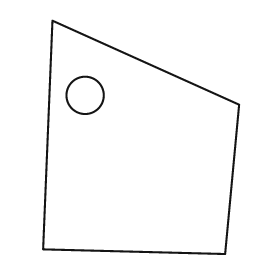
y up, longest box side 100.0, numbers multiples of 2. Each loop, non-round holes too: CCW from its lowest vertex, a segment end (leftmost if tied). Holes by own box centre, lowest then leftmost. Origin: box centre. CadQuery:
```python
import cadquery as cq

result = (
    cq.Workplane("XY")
    .moveTo(36.0, -50.0)
    .lineTo(42.0, 14.0)
    .lineTo(-38.0, 50.0)
    .lineTo(-42.0, -48.0)
    .close()
    .moveTo(-24.0, 18.0)
    .circle(8.0)
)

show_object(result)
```